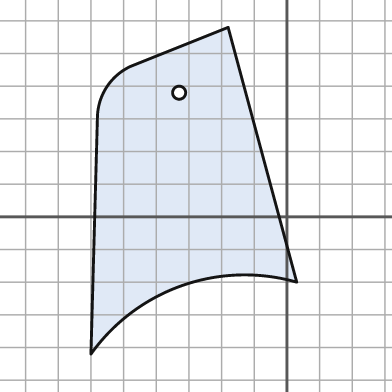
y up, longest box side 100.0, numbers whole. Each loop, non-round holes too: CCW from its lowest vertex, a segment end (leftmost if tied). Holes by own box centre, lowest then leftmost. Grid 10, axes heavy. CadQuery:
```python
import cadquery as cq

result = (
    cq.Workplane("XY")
    .moveTo(-60.0, -42.0)
    .threePointArc((-32.0, -21.0), (3.0, -20.0))
    .lineTo(-18.0, 58.0)
    .lineTo(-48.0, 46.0)
    .threePointArc((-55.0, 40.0), (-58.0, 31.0))
    .close()
    .moveTo(-33.0, 38.0)
    .circle(2.0)
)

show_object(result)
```